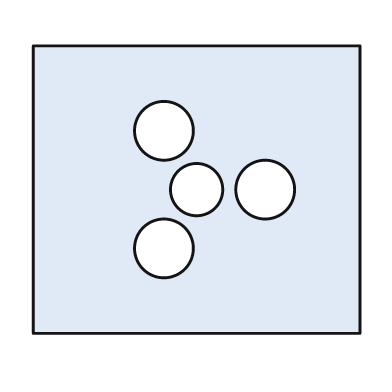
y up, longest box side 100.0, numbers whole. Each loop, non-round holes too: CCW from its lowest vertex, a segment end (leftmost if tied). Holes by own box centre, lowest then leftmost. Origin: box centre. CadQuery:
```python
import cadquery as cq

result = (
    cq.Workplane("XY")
    .moveTo(-50.0, -44.0)
    .lineTo(50.0, -44.0)
    .lineTo(50.0, 44.0)
    .lineTo(-50.0, 44.0)
    .close()
    .moveTo(-10.0, -18.0)
    .circle(9.0)
    .moveTo(0.0, 0.0)
    .circle(8.0)
    .moveTo(21.0, 0.0)
    .circle(9.0)
    .moveTo(-10.0, 18.0)
    .circle(9.0)
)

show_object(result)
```